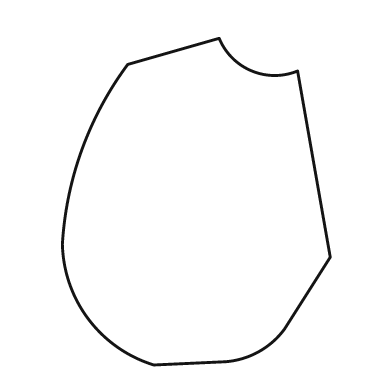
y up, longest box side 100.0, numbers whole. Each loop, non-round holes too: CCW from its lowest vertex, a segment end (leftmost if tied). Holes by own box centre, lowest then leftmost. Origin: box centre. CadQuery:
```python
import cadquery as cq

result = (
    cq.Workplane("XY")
    .moveTo(-13.0, -50.0)
    .lineTo(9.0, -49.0)
    .threePointArc((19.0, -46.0), (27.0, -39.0))
    .lineTo(41.0, -17.0)
    .lineTo(31.0, 40.0)
    .threePointArc((17.0, 40.0), (7.0, 50.0))
    .lineTo(-21.0, 42.0)
    .threePointArc((-35.0, 16.0), (-41.0, -13.0))
    .threePointArc((-33.0, -36.0), (-13.0, -50.0))
    .close()
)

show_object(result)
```